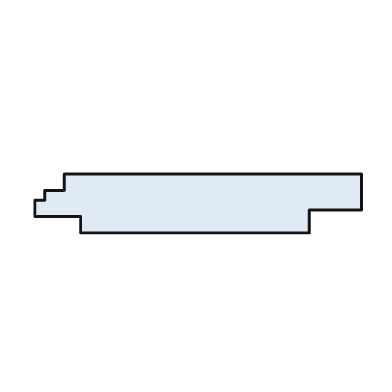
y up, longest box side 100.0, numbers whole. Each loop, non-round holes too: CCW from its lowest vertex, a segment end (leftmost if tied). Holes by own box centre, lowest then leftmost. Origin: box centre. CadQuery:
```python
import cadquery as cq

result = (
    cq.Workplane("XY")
    .moveTo(-36.0, -9.0)
    .lineTo(34.0, -9.0)
    .lineTo(34.0, -2.0)
    .lineTo(50.0, -2.0)
    .lineTo(50.0, 9.0)
    .lineTo(-41.0, 9.0)
    .lineTo(-41.0, 4.0)
    .lineTo(-47.0, 4.0)
    .lineTo(-47.0, 1.0)
    .lineTo(-50.0, 1.0)
    .lineTo(-50.0, -4.0)
    .lineTo(-36.0, -4.0)
    .close()
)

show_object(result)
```